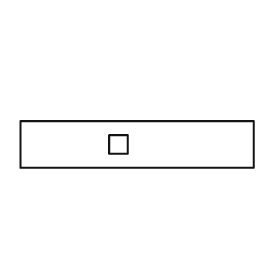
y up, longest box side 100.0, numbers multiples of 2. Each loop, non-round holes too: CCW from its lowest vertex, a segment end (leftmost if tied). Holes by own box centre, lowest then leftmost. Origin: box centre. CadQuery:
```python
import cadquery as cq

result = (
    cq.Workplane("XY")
    .moveTo(-50.0, -10.0)
    .lineTo(50.0, -10.0)
    .lineTo(50.0, 10.0)
    .lineTo(-50.0, 10.0)
    .close()
    .moveTo(-12.0, -4.0)
    .lineTo(-4.0, -4.0)
    .lineTo(-4.0, 4.0)
    .lineTo(-12.0, 4.0)
    .close()
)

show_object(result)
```